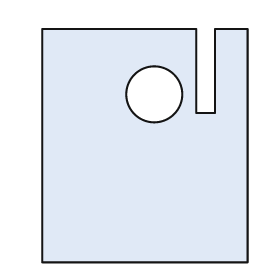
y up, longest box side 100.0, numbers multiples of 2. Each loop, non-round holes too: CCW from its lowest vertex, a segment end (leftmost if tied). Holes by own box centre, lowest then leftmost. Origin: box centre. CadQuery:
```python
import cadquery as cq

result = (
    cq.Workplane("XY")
    .moveTo(-44.0, -50.0)
    .lineTo(44.0, -50.0)
    .lineTo(44.0, 50.0)
    .lineTo(30.0, 50.0)
    .lineTo(30.0, 14.0)
    .lineTo(22.0, 14.0)
    .lineTo(22.0, 50.0)
    .lineTo(-44.0, 50.0)
    .close()
    .moveTo(4.0, 22.0)
    .circle(12.0)
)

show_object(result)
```